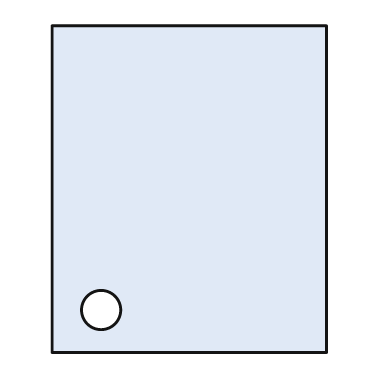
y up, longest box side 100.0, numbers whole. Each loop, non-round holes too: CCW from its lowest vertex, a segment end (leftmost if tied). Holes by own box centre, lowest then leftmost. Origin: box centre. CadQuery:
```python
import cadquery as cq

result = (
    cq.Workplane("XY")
    .moveTo(-42.0, -50.0)
    .lineTo(42.0, -50.0)
    .lineTo(42.0, 50.0)
    .lineTo(-42.0, 50.0)
    .close()
    .moveTo(-27.0, -37.0)
    .circle(6.0)
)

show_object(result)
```